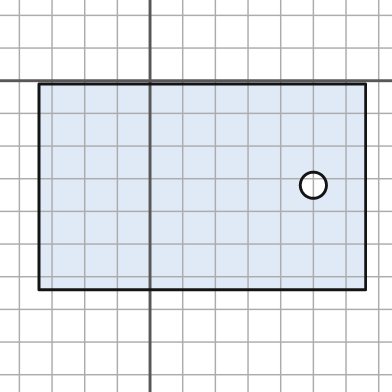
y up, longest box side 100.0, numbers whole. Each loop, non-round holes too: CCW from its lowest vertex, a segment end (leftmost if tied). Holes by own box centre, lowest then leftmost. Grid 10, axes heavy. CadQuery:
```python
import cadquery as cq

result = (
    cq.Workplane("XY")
    .moveTo(-34.0, -64.0)
    .lineTo(66.0, -64.0)
    .lineTo(66.0, -1.0)
    .lineTo(-34.0, -1.0)
    .close()
    .moveTo(50.0, -32.0)
    .circle(4.0)
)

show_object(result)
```